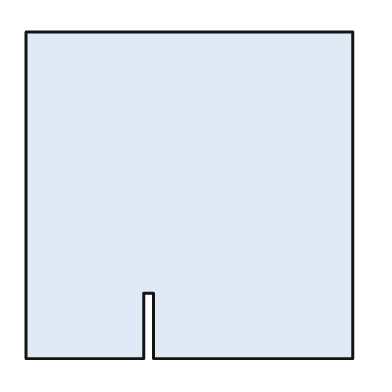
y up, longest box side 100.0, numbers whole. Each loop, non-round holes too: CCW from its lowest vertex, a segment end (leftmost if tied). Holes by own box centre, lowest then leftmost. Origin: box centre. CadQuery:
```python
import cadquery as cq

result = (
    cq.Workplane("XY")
    .moveTo(-50.0, -50.0)
    .lineTo(-14.0, -50.0)
    .lineTo(-14.0, -30.0)
    .lineTo(-11.0, -30.0)
    .lineTo(-11.0, -50.0)
    .lineTo(50.0, -50.0)
    .lineTo(50.0, 50.0)
    .lineTo(-50.0, 50.0)
    .close()
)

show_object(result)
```